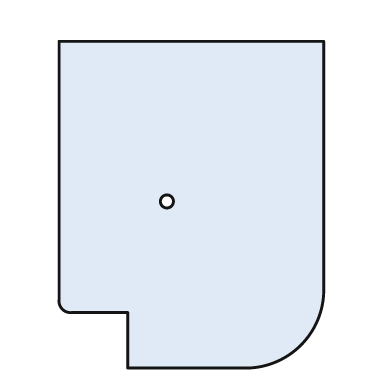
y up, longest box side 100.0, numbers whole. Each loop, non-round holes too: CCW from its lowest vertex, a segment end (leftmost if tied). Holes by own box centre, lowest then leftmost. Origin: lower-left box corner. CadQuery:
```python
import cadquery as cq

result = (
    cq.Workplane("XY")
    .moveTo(21.0, 0.0)
    .lineTo(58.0, 0.0)
    .threePointArc((74.0, 7.0), (81.0, 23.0))
    .lineTo(81.0, 100.0)
    .lineTo(0.0, 100.0)
    .lineTo(0.0, 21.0)
    .threePointArc((1.0, 18.0), (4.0, 17.0))
    .lineTo(21.0, 17.0)
    .close()
    .moveTo(33.0, 51.0)
    .circle(2.0)
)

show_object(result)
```